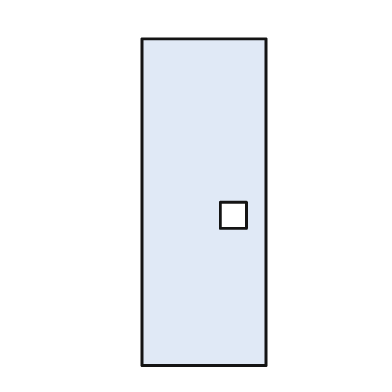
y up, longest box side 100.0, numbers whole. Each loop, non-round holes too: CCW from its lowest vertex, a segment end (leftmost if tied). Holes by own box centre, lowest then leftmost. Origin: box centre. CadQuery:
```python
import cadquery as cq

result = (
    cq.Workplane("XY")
    .moveTo(-19.0, -50.0)
    .lineTo(19.0, -50.0)
    .lineTo(19.0, 50.0)
    .lineTo(-19.0, 50.0)
    .close()
    .moveTo(5.0, -8.0)
    .lineTo(13.0, -8.0)
    .lineTo(13.0, 0.0)
    .lineTo(5.0, 0.0)
    .close()
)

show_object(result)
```